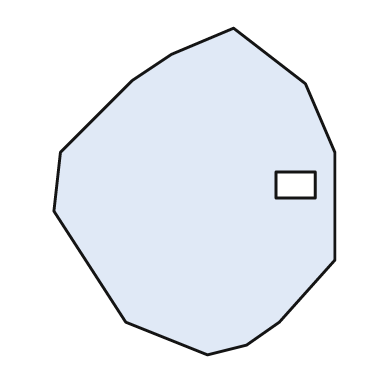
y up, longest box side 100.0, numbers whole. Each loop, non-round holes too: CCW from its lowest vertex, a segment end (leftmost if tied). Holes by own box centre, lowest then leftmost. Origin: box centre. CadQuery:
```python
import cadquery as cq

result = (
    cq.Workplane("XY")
    .moveTo(4.0, -50.0)
    .lineTo(16.0, -47.0)
    .lineTo(26.0, -40.0)
    .lineTo(43.0, -21.0)
    .lineTo(43.0, 12.0)
    .lineTo(34.0, 33.0)
    .lineTo(12.0, 50.0)
    .lineTo(-7.0, 42.0)
    .lineTo(-19.0, 34.0)
    .lineTo(-41.0, 12.0)
    .lineTo(-43.0, -6.0)
    .lineTo(-21.0, -40.0)
    .close()
    .moveTo(25.0, -2.0)
    .lineTo(37.0, -2.0)
    .lineTo(37.0, 6.0)
    .lineTo(25.0, 6.0)
    .close()
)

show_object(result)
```